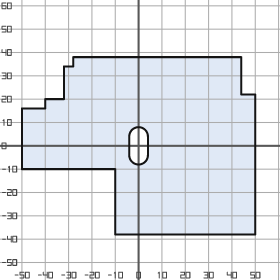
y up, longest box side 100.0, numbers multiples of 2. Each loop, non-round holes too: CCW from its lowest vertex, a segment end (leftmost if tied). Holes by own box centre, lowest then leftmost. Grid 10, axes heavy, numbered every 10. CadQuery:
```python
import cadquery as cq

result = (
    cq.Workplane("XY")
    .moveTo(-10.0, -38.0)
    .lineTo(50.0, -38.0)
    .lineTo(50.0, 22.0)
    .lineTo(44.0, 22.0)
    .lineTo(44.0, 38.0)
    .lineTo(-28.0, 38.0)
    .lineTo(-28.0, 34.0)
    .lineTo(-32.0, 34.0)
    .lineTo(-32.0, 20.0)
    .lineTo(-40.0, 20.0)
    .lineTo(-40.0, 16.0)
    .lineTo(-50.0, 16.0)
    .lineTo(-50.0, -10.0)
    .lineTo(-10.0, -10.0)
    .close()
    .moveTo(-4.0, -4.0)
    .threePointArc((0.0, -8.0), (4.0, -4.0))
    .lineTo(4.0, 4.0)
    .threePointArc((0.0, 8.0), (-4.0, 4.0))
    .close()
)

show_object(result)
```